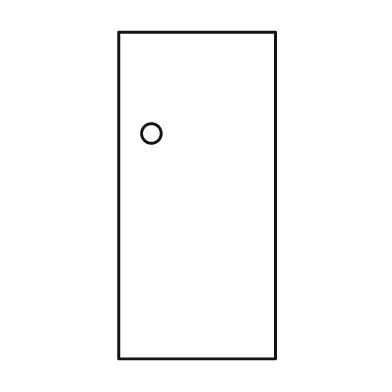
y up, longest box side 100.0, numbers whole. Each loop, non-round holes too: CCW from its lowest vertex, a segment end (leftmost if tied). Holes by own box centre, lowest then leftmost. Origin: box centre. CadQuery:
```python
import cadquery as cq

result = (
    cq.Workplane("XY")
    .moveTo(-24.0, -50.0)
    .lineTo(24.0, -50.0)
    .lineTo(24.0, 50.0)
    .lineTo(-24.0, 50.0)
    .close()
    .moveTo(-14.0, 19.0)
    .circle(3.0)
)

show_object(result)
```